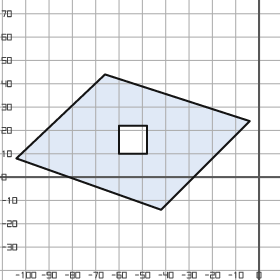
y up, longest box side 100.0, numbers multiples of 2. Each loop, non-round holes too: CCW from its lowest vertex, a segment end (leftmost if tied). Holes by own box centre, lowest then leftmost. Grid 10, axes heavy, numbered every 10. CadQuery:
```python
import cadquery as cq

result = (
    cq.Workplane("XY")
    .moveTo(-42.0, -14.0)
    .lineTo(-4.0, 24.0)
    .lineTo(-66.0, 44.0)
    .lineTo(-104.0, 8.0)
    .close()
    .moveTo(-60.0, 10.0)
    .lineTo(-48.0, 10.0)
    .lineTo(-48.0, 22.0)
    .lineTo(-60.0, 22.0)
    .close()
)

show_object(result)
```